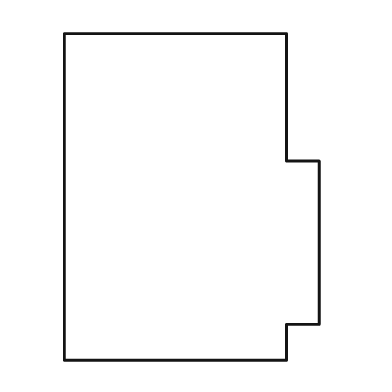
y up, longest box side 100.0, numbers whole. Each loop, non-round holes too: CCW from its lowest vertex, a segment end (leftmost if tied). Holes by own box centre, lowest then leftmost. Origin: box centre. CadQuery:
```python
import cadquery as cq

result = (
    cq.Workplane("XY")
    .moveTo(-39.0, -50.0)
    .lineTo(29.0, -50.0)
    .lineTo(29.0, -39.0)
    .lineTo(39.0, -39.0)
    .lineTo(39.0, 11.0)
    .lineTo(29.0, 11.0)
    .lineTo(29.0, 50.0)
    .lineTo(-39.0, 50.0)
    .close()
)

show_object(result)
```